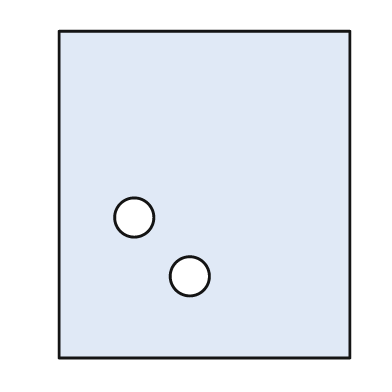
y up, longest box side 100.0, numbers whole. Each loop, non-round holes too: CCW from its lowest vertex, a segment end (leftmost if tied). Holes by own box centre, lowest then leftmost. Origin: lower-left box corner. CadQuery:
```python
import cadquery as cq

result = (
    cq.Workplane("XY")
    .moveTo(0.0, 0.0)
    .lineTo(89.0, 0.0)
    .lineTo(89.0, 100.0)
    .lineTo(0.0, 100.0)
    .close()
    .moveTo(40.0, 25.0)
    .circle(6.0)
    .moveTo(23.0, 43.0)
    .circle(6.0)
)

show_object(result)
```